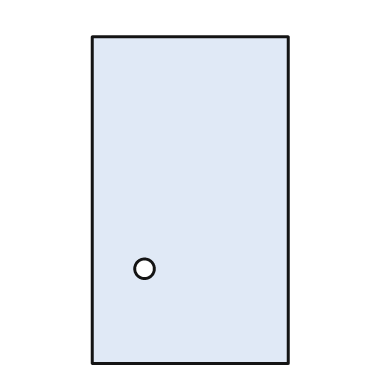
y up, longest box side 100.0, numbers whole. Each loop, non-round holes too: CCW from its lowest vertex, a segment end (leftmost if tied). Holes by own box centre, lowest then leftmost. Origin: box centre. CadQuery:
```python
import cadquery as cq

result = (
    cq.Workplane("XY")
    .moveTo(-30.0, -50.0)
    .lineTo(30.0, -50.0)
    .lineTo(30.0, 50.0)
    .lineTo(-30.0, 50.0)
    .close()
    .moveTo(-14.0, -21.0)
    .circle(3.0)
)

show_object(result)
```